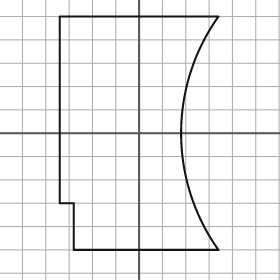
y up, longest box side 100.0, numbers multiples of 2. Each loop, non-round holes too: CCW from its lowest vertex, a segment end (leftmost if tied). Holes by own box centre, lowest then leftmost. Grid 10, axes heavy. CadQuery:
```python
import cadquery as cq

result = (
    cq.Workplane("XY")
    .moveTo(-28.0, -50.0)
    .lineTo(34.0, -50.0)
    .threePointArc((18.0, 0.0), (34.0, 50.0))
    .lineTo(-34.0, 50.0)
    .lineTo(-34.0, -30.0)
    .lineTo(-28.0, -30.0)
    .close()
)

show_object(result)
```